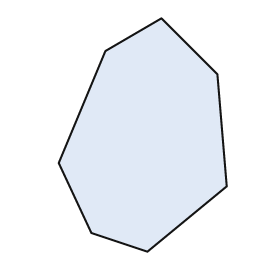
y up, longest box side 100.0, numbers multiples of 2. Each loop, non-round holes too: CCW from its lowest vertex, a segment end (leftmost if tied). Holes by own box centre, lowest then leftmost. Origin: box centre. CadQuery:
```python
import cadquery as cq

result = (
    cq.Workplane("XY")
    .moveTo(2.0, -50.0)
    .lineTo(36.0, -22.0)
    .lineTo(32.0, 26.0)
    .lineTo(8.0, 50.0)
    .lineTo(-16.0, 36.0)
    .lineTo(-36.0, -12.0)
    .lineTo(-22.0, -42.0)
    .close()
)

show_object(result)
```